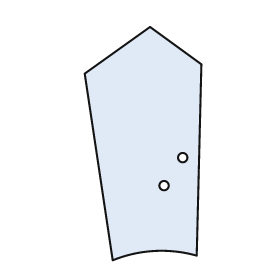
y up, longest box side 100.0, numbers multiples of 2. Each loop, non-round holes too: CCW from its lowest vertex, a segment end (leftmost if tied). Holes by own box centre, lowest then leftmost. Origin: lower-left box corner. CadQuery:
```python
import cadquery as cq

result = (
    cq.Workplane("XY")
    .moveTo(12.0, 0.0)
    .threePointArc((30.0, 4.0), (48.0, 2.0))
    .lineTo(50.0, 84.0)
    .lineTo(28.0, 100.0)
    .lineTo(0.0, 80.0)
    .close()
    .moveTo(34.0, 32.0)
    .circle(2.0)
    .moveTo(42.0, 44.0)
    .circle(2.0)
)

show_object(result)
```